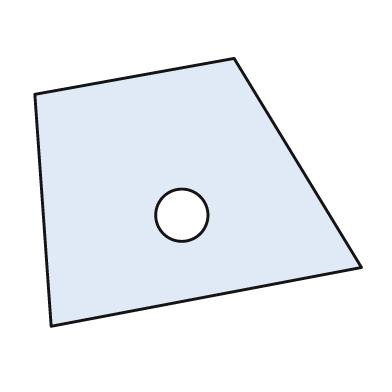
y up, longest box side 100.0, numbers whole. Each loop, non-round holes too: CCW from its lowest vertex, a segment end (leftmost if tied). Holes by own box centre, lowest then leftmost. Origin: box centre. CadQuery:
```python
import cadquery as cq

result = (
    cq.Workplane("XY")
    .moveTo(-45.0, -41.0)
    .lineTo(50.0, -23.0)
    .lineTo(11.0, 41.0)
    .lineTo(-50.0, 30.0)
    .close()
    .moveTo(-5.0, -7.0)
    .circle(8.0)
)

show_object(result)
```